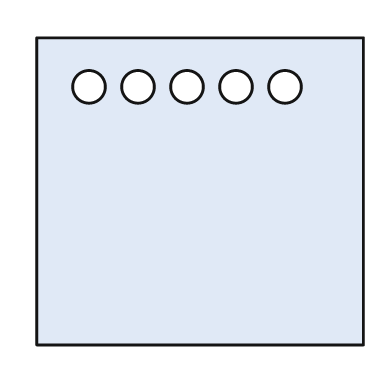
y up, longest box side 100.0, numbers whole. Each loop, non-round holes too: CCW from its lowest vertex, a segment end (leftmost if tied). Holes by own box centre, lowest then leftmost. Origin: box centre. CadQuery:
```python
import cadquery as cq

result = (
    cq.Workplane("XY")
    .moveTo(-50.0, -47.0)
    .lineTo(50.0, -47.0)
    .lineTo(50.0, 47.0)
    .lineTo(-50.0, 47.0)
    .close()
    .moveTo(-34.0, 32.0)
    .circle(5.0)
    .moveTo(-19.0, 32.0)
    .circle(5.0)
    .moveTo(-4.0, 32.0)
    .circle(5.0)
    .moveTo(11.0, 32.0)
    .circle(5.0)
    .moveTo(26.0, 32.0)
    .circle(5.0)
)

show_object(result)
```